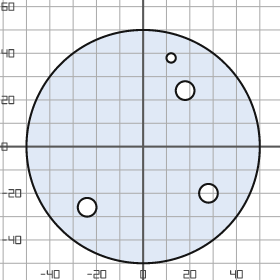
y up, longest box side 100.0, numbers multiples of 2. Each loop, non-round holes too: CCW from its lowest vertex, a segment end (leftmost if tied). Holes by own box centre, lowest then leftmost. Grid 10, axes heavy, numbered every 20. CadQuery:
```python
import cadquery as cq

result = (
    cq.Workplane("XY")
    .moveTo(0.0, 0.0)
    .circle(50.0)
    .moveTo(-24.0, -26.0)
    .circle(4.0)
    .moveTo(28.0, -20.0)
    .circle(4.0)
    .moveTo(18.0, 24.0)
    .circle(4.0)
    .moveTo(12.0, 38.0)
    .circle(2.0)
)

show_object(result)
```